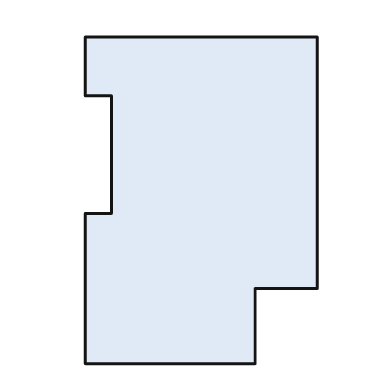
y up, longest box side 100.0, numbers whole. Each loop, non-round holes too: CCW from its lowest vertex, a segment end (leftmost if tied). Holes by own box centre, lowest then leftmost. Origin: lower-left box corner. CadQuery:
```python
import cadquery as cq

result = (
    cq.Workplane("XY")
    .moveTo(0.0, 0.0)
    .lineTo(52.0, 0.0)
    .lineTo(52.0, 23.0)
    .lineTo(71.0, 23.0)
    .lineTo(71.0, 100.0)
    .lineTo(0.0, 100.0)
    .lineTo(0.0, 82.0)
    .lineTo(8.0, 82.0)
    .lineTo(8.0, 46.0)
    .lineTo(0.0, 46.0)
    .close()
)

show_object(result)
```